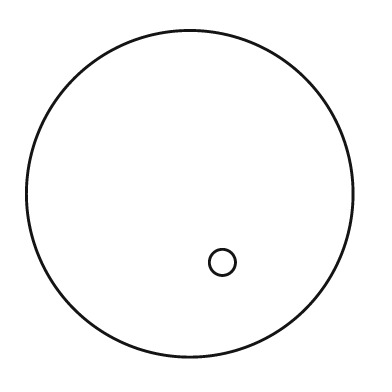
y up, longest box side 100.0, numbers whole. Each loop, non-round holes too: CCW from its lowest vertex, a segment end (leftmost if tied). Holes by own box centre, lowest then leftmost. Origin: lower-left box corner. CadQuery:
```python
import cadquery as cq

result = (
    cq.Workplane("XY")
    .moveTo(50.0, 50.0)
    .circle(50.0)
    .moveTo(60.0, 29.0)
    .circle(4.0)
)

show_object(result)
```